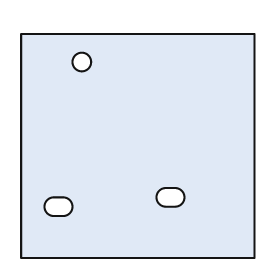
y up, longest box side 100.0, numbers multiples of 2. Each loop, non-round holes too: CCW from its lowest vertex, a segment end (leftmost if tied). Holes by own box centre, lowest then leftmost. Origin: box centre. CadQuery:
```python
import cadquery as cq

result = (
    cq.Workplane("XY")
    .moveTo(-50.0, -48.0)
    .lineTo(50.0, -48.0)
    .lineTo(50.0, 48.0)
    .lineTo(-50.0, 48.0)
    .close()
    .moveTo(-36.0, -30.0)
    .lineTo(-32.0, -30.0)
    .threePointArc((-28.0, -26.0), (-32.0, -22.0))
    .lineTo(-36.0, -22.0)
    .threePointArc((-40.0, -26.0), (-36.0, -30.0))
    .close()
    .moveTo(12.0, -26.0)
    .lineTo(16.0, -26.0)
    .threePointArc((20.0, -22.0), (16.0, -18.0))
    .lineTo(12.0, -18.0)
    .threePointArc((8.0, -22.0), (12.0, -26.0))
    .close()
    .moveTo(-24.0, 36.0)
    .circle(4.0)
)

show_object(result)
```